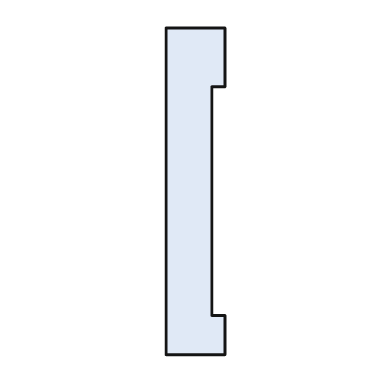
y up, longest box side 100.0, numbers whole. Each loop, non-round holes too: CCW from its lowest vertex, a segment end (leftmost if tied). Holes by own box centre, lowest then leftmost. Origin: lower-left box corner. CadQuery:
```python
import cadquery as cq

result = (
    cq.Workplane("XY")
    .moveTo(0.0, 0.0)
    .lineTo(18.0, 0.0)
    .lineTo(18.0, 12.0)
    .lineTo(14.0, 12.0)
    .lineTo(14.0, 82.0)
    .lineTo(18.0, 82.0)
    .lineTo(18.0, 100.0)
    .lineTo(0.0, 100.0)
    .close()
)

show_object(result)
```